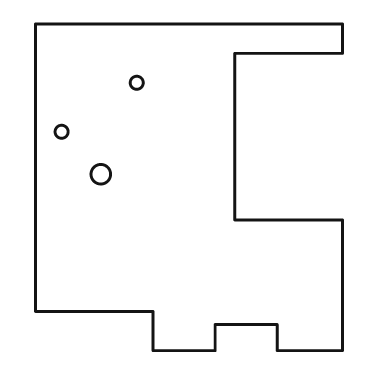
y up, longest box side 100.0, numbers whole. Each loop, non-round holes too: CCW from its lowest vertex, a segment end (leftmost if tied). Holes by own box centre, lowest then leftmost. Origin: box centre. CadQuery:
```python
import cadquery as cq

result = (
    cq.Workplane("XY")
    .moveTo(-11.0, -50.0)
    .lineTo(8.0, -50.0)
    .lineTo(8.0, -42.0)
    .lineTo(27.0, -42.0)
    .lineTo(27.0, -50.0)
    .lineTo(47.0, -50.0)
    .lineTo(47.0, -10.0)
    .lineTo(14.0, -10.0)
    .lineTo(14.0, 41.0)
    .lineTo(47.0, 41.0)
    .lineTo(47.0, 50.0)
    .lineTo(-47.0, 50.0)
    .lineTo(-47.0, -38.0)
    .lineTo(-11.0, -38.0)
    .close()
    .moveTo(-27.0, 4.0)
    .circle(3.0)
    .moveTo(-39.0, 17.0)
    .circle(2.0)
    .moveTo(-16.0, 32.0)
    .circle(2.0)
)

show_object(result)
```